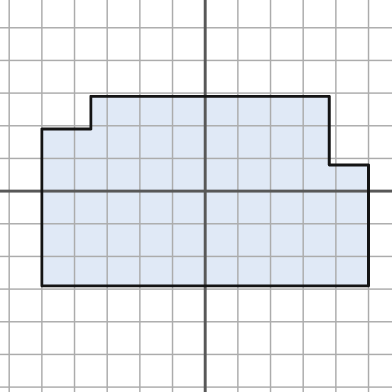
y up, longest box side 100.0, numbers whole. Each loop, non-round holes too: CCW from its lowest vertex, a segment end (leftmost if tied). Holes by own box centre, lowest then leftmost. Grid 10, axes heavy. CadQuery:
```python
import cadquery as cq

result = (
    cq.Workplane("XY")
    .moveTo(-50.0, -29.0)
    .lineTo(50.0, -29.0)
    .lineTo(50.0, 8.0)
    .lineTo(38.0, 8.0)
    .lineTo(38.0, 29.0)
    .lineTo(-35.0, 29.0)
    .lineTo(-35.0, 19.0)
    .lineTo(-50.0, 19.0)
    .close()
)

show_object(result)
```